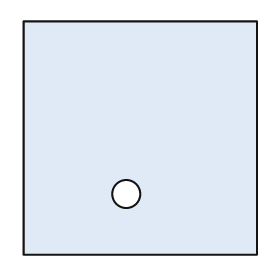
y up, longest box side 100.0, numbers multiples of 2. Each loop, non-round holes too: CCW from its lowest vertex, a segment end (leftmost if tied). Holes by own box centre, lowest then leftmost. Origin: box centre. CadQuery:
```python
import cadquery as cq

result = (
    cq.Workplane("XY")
    .moveTo(-50.0, -50.0)
    .lineTo(50.0, -50.0)
    .lineTo(50.0, 50.0)
    .lineTo(-50.0, 50.0)
    .close()
    .moveTo(-6.0, -24.0)
    .circle(6.0)
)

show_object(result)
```